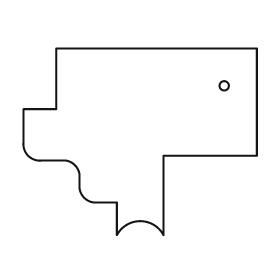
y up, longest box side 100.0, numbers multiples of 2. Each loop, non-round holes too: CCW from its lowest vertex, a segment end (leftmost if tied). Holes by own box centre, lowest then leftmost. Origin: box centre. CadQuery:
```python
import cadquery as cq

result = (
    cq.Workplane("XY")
    .moveTo(-10.0, -40.0)
    .threePointArc((0.0, -34.0), (10.0, -40.0))
    .lineTo(10.0, -6.0)
    .lineTo(50.0, -6.0)
    .lineTo(50.0, 40.0)
    .lineTo(-36.0, 40.0)
    .lineTo(-36.0, 14.0)
    .lineTo(-50.0, 14.0)
    .lineTo(-50.0, 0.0)
    .threePointArc((-48.0, -6.0), (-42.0, -8.0))
    .lineTo(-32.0, -8.0)
    .threePointArc((-28.0, -10.0), (-26.0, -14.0))
    .lineTo(-26.0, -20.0)
    .threePointArc((-24.0, -24.0), (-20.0, -26.0))
    .lineTo(-10.0, -26.0)
    .close()
    .moveTo(36.0, 24.0)
    .circle(2.0)
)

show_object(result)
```